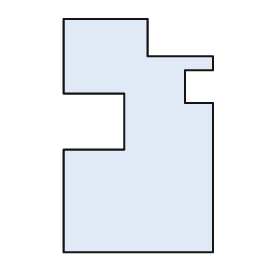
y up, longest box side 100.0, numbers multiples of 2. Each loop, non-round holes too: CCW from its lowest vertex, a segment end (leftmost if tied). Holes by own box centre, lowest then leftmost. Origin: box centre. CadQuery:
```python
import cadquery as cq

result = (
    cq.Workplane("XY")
    .moveTo(-32.0, -50.0)
    .lineTo(32.0, -50.0)
    .lineTo(32.0, 14.0)
    .lineTo(20.0, 14.0)
    .lineTo(20.0, 28.0)
    .lineTo(32.0, 28.0)
    .lineTo(32.0, 34.0)
    .lineTo(4.0, 34.0)
    .lineTo(4.0, 50.0)
    .lineTo(-32.0, 50.0)
    .lineTo(-32.0, 18.0)
    .lineTo(-6.0, 18.0)
    .lineTo(-6.0, -6.0)
    .lineTo(-32.0, -6.0)
    .close()
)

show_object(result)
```